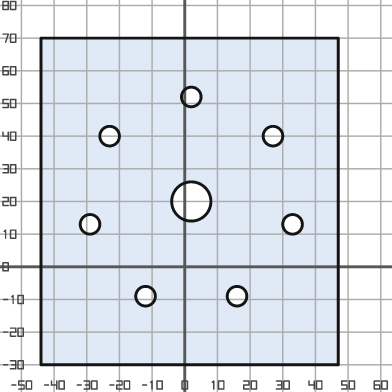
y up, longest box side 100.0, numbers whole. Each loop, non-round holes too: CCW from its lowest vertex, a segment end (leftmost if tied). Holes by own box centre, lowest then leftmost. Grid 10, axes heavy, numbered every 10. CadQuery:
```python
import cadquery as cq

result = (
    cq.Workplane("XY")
    .moveTo(-44.0, -30.0)
    .lineTo(47.0, -30.0)
    .lineTo(47.0, 70.0)
    .lineTo(-44.0, 70.0)
    .close()
    .moveTo(-12.0, -9.0)
    .circle(3.0)
    .moveTo(16.0, -9.0)
    .circle(3.0)
    .moveTo(-29.0, 13.0)
    .circle(3.0)
    .moveTo(33.0, 13.0)
    .circle(3.0)
    .moveTo(2.0, 20.0)
    .circle(6.0)
    .moveTo(-23.0, 40.0)
    .circle(3.0)
    .moveTo(27.0, 40.0)
    .circle(3.0)
    .moveTo(2.0, 52.0)
    .circle(3.0)
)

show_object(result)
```